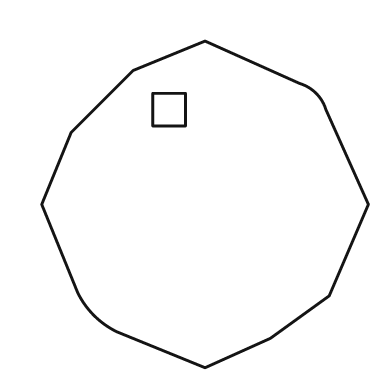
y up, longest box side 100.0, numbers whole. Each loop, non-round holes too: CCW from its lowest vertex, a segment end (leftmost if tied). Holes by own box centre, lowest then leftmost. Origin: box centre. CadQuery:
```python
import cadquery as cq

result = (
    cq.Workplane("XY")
    .moveTo(0.0, -50.0)
    .lineTo(20.0, -41.0)
    .lineTo(38.0, -28.0)
    .lineTo(50.0, 0.0)
    .lineTo(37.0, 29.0)
    .threePointArc((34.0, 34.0), (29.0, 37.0))
    .lineTo(0.0, 50.0)
    .lineTo(-22.0, 41.0)
    .lineTo(-41.0, 22.0)
    .lineTo(-50.0, 0.0)
    .lineTo(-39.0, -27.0)
    .threePointArc((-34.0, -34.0), (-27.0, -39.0))
    .close()
    .moveTo(-16.0, 24.0)
    .lineTo(-6.0, 24.0)
    .lineTo(-6.0, 34.0)
    .lineTo(-16.0, 34.0)
    .close()
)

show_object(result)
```